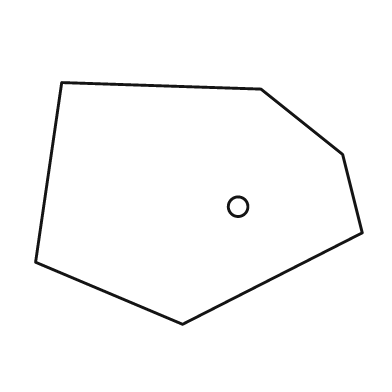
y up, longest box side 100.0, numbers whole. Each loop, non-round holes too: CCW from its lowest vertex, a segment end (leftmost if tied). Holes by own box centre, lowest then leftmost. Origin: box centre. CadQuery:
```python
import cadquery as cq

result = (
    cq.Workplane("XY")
    .moveTo(-5.0, -37.0)
    .lineTo(50.0, -9.0)
    .lineTo(44.0, 15.0)
    .lineTo(19.0, 35.0)
    .lineTo(-42.0, 37.0)
    .lineTo(-50.0, -18.0)
    .close()
    .moveTo(12.0, -1.0)
    .circle(3.0)
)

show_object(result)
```